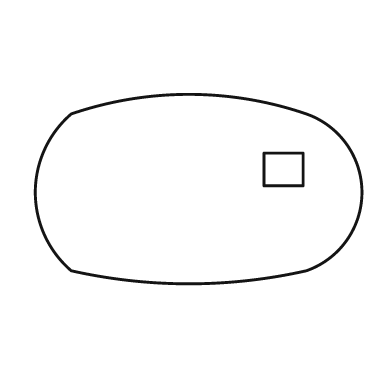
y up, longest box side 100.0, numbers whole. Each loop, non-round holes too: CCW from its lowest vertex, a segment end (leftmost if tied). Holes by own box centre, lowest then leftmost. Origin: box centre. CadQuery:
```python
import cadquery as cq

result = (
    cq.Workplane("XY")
    .moveTo(-39.0, -25.0)
    .threePointArc((-3.0, -29.0), (33.0, -25.0))
    .threePointArc((50.0, -1.0), (33.0, 23.0))
    .threePointArc((-3.0, 29.0), (-39.0, 23.0))
    .threePointArc((-50.0, -1.0), (-39.0, -25.0))
    .close()
    .moveTo(20.0, 1.0)
    .lineTo(32.0, 1.0)
    .lineTo(32.0, 11.0)
    .lineTo(20.0, 11.0)
    .close()
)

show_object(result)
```